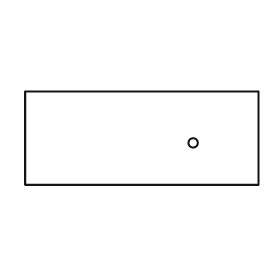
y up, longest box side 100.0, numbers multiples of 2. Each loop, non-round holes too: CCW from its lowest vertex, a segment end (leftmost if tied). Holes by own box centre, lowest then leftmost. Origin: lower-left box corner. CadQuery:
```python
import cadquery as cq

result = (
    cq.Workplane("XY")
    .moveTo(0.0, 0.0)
    .lineTo(100.0, 0.0)
    .lineTo(100.0, 40.0)
    .lineTo(0.0, 40.0)
    .close()
    .moveTo(72.0, 18.0)
    .circle(2.0)
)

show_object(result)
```